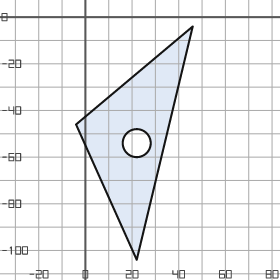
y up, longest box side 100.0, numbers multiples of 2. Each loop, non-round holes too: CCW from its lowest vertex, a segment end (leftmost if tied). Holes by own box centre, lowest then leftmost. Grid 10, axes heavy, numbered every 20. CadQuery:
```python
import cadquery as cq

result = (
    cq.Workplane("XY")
    .moveTo(22.0, -104.0)
    .lineTo(46.0, -4.0)
    .lineTo(-4.0, -46.0)
    .close()
    .moveTo(22.0, -54.0)
    .circle(6.0)
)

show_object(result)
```